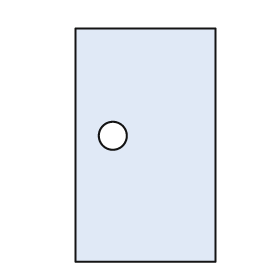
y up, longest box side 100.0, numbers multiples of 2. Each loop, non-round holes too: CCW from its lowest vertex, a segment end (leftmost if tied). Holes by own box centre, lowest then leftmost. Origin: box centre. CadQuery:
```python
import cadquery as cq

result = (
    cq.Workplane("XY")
    .moveTo(-30.0, -50.0)
    .lineTo(30.0, -50.0)
    .lineTo(30.0, 50.0)
    .lineTo(-30.0, 50.0)
    .close()
    .moveTo(-14.0, 4.0)
    .circle(6.0)
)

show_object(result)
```